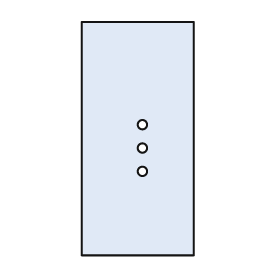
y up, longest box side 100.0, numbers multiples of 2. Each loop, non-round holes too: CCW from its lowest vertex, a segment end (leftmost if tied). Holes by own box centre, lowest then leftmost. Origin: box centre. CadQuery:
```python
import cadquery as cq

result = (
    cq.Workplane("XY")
    .moveTo(-24.0, -50.0)
    .lineTo(24.0, -50.0)
    .lineTo(24.0, 50.0)
    .lineTo(-24.0, 50.0)
    .close()
    .moveTo(2.0, -14.0)
    .circle(2.0)
    .moveTo(2.0, -4.0)
    .circle(2.0)
    .moveTo(2.0, 6.0)
    .circle(2.0)
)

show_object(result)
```